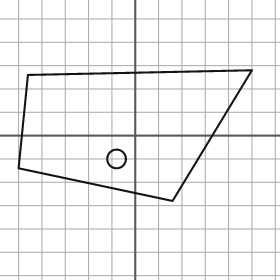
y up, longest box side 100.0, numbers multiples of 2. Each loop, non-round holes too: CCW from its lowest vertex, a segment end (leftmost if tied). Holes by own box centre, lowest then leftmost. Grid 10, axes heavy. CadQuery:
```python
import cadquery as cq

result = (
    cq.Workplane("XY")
    .moveTo(16.0, -28.0)
    .lineTo(50.0, 28.0)
    .lineTo(-46.0, 26.0)
    .lineTo(-50.0, -14.0)
    .close()
    .moveTo(-8.0, -10.0)
    .circle(4.0)
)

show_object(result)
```